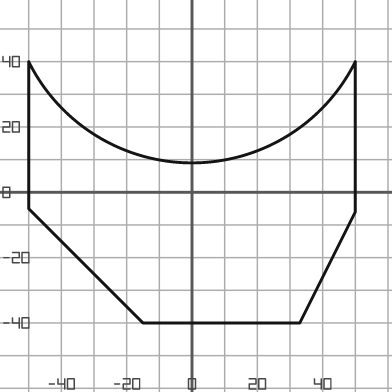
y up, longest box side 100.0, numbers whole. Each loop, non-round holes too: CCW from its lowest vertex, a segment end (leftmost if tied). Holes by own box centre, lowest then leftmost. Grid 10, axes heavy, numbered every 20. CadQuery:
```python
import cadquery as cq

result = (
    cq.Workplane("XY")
    .moveTo(-15.0, -40.0)
    .lineTo(33.0, -40.0)
    .lineTo(50.0, -6.0)
    .lineTo(50.0, 40.0)
    .threePointArc((0.0, 9.0), (-50.0, 40.0))
    .lineTo(-50.0, -5.0)
    .close()
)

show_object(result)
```